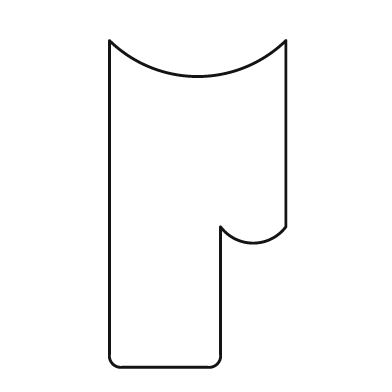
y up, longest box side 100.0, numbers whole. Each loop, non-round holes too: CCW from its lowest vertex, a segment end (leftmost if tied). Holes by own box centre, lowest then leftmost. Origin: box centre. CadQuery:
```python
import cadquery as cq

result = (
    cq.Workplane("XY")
    .moveTo(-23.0, -50.0)
    .lineTo(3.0, -50.0)
    .threePointArc((6.0, -49.0), (7.0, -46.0))
    .lineTo(7.0, -7.0)
    .threePointArc((17.0, -12.0), (27.0, -7.0))
    .lineTo(27.0, 50.0)
    .threePointArc((0.0, 39.0), (-27.0, 50.0))
    .lineTo(-27.0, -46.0)
    .threePointArc((-26.0, -49.0), (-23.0, -50.0))
    .close()
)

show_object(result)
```